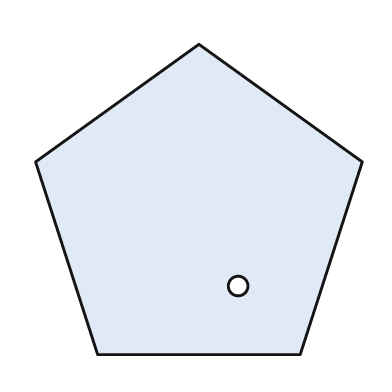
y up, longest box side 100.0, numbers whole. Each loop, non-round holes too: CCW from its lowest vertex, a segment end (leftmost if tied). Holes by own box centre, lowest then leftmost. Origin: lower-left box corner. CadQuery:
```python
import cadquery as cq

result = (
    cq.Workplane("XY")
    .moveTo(19.0, 0.0)
    .lineTo(81.0, 0.0)
    .lineTo(100.0, 59.0)
    .lineTo(50.0, 95.0)
    .lineTo(0.0, 59.0)
    .close()
    .moveTo(62.0, 21.0)
    .circle(3.0)
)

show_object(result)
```